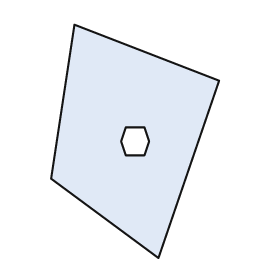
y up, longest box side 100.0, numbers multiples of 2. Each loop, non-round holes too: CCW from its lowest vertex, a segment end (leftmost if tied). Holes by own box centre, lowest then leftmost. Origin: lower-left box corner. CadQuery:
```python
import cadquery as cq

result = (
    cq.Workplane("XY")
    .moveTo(46.0, 0.0)
    .lineTo(72.0, 76.0)
    .lineTo(10.0, 100.0)
    .lineTo(0.0, 34.0)
    .close()
    .moveTo(32.0, 44.0)
    .lineTo(40.0, 44.0)
    .lineTo(42.0, 50.0)
    .lineTo(40.0, 56.0)
    .lineTo(32.0, 56.0)
    .lineTo(30.0, 50.0)
    .close()
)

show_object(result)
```